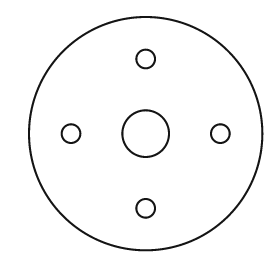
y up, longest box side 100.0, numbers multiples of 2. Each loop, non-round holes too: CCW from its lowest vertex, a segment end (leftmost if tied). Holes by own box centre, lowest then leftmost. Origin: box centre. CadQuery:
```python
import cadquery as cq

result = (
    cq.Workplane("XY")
    .moveTo(0.0, 0.0)
    .circle(50.0)
    .moveTo(0.0, -32.0)
    .circle(4.0)
    .moveTo(-32.0, 0.0)
    .circle(4.0)
    .moveTo(0.0, 0.0)
    .circle(10.0)
    .moveTo(32.0, 0.0)
    .circle(4.0)
    .moveTo(0.0, 32.0)
    .circle(4.0)
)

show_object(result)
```